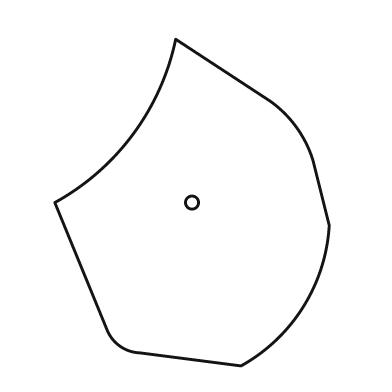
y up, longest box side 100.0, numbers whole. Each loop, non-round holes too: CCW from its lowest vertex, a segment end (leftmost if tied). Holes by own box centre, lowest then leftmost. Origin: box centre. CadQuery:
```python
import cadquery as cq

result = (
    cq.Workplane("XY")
    .moveTo(15.0, -50.0)
    .threePointArc((34.0, -32.0), (42.0, -7.0))
    .lineTo(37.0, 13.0)
    .threePointArc((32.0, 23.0), (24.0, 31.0))
    .lineTo(-5.0, 50.0)
    .threePointArc((-18.0, 21.0), (-42.0, 0.0))
    .lineTo(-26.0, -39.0)
    .threePointArc((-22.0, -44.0), (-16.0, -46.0))
    .close()
    .moveTo(0.0, 0.0)
    .circle(2.0)
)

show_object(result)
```